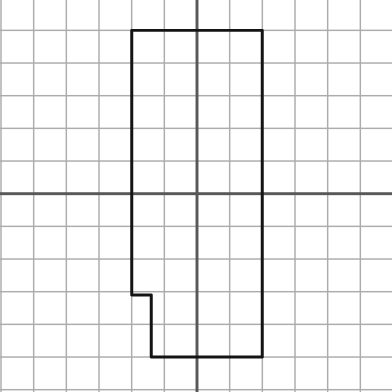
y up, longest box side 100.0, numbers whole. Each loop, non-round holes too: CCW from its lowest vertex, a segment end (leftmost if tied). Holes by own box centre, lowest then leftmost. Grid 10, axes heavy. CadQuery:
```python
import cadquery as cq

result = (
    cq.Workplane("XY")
    .moveTo(-14.0, -50.0)
    .lineTo(20.0, -50.0)
    .lineTo(20.0, 50.0)
    .lineTo(-20.0, 50.0)
    .lineTo(-20.0, -31.0)
    .lineTo(-14.0, -31.0)
    .close()
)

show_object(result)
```